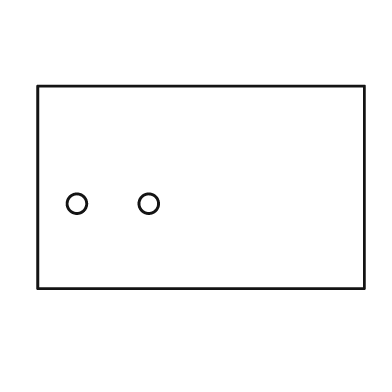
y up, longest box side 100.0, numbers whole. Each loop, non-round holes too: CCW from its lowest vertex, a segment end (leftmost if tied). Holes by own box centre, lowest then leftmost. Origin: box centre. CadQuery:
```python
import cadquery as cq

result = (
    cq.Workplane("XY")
    .moveTo(-50.0, -31.0)
    .lineTo(50.0, -31.0)
    .lineTo(50.0, 31.0)
    .lineTo(-50.0, 31.0)
    .close()
    .moveTo(-38.0, -5.0)
    .circle(3.0)
    .moveTo(-16.0, -5.0)
    .circle(3.0)
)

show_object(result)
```